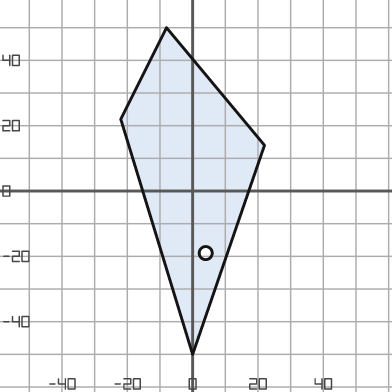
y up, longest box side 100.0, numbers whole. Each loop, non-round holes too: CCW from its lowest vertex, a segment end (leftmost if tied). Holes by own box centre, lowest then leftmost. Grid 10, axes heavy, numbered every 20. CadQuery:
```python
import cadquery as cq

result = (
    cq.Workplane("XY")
    .moveTo(0.0, -50.0)
    .lineTo(22.0, 14.0)
    .lineTo(-8.0, 50.0)
    .lineTo(-22.0, 22.0)
    .close()
    .moveTo(4.0, -19.0)
    .circle(2.0)
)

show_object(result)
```